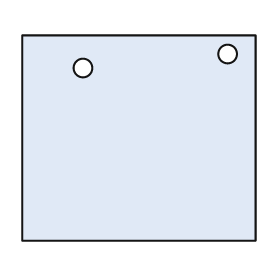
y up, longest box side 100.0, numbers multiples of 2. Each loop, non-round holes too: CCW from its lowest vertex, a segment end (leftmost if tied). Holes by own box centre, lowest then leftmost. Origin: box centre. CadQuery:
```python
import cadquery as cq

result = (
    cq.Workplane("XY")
    .moveTo(-50.0, -44.0)
    .lineTo(50.0, -44.0)
    .lineTo(50.0, 44.0)
    .lineTo(-50.0, 44.0)
    .close()
    .moveTo(-24.0, 30.0)
    .circle(4.0)
    .moveTo(38.0, 36.0)
    .circle(4.0)
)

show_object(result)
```